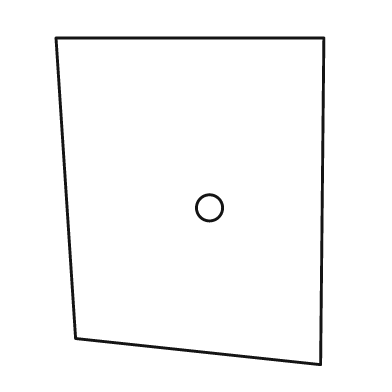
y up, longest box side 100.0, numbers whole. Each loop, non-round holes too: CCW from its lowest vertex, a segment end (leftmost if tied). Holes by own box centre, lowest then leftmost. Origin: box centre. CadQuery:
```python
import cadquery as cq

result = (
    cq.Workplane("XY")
    .moveTo(40.0, -50.0)
    .lineTo(41.0, 50.0)
    .lineTo(-41.0, 50.0)
    .lineTo(-35.0, -42.0)
    .close()
    .moveTo(6.0, -2.0)
    .circle(4.0)
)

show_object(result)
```